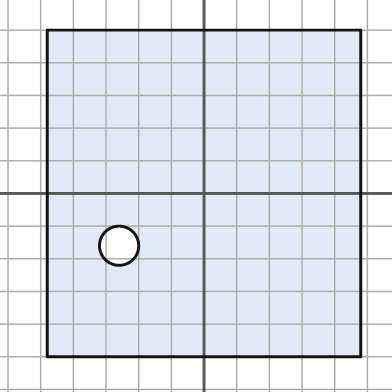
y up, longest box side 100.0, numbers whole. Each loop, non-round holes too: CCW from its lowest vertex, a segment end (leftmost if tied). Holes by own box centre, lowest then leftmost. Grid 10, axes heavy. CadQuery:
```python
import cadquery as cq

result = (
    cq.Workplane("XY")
    .moveTo(-48.0, -50.0)
    .lineTo(48.0, -50.0)
    .lineTo(48.0, 50.0)
    .lineTo(-48.0, 50.0)
    .close()
    .moveTo(-26.0, -16.0)
    .circle(6.0)
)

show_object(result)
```